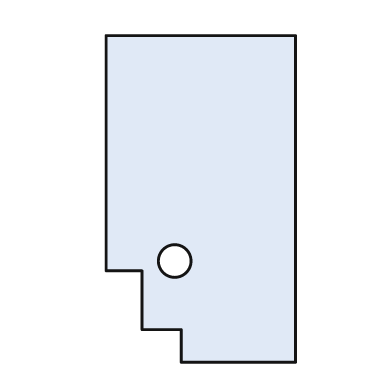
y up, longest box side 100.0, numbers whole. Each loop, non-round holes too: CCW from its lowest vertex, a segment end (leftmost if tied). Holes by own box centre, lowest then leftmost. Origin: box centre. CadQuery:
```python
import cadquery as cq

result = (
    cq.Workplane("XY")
    .moveTo(-6.0, -50.0)
    .lineTo(29.0, -50.0)
    .lineTo(29.0, 50.0)
    .lineTo(-29.0, 50.0)
    .lineTo(-29.0, -22.0)
    .lineTo(-18.0, -22.0)
    .lineTo(-18.0, -40.0)
    .lineTo(-6.0, -40.0)
    .close()
    .moveTo(-8.0, -19.0)
    .circle(5.0)
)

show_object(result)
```